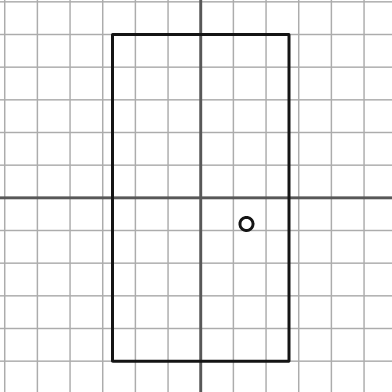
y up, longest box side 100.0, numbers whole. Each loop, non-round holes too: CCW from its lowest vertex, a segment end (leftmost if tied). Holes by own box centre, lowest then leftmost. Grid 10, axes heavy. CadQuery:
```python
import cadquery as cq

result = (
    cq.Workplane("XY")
    .moveTo(-27.0, -50.0)
    .lineTo(27.0, -50.0)
    .lineTo(27.0, 50.0)
    .lineTo(-27.0, 50.0)
    .close()
    .moveTo(14.0, -8.0)
    .circle(2.0)
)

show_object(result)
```